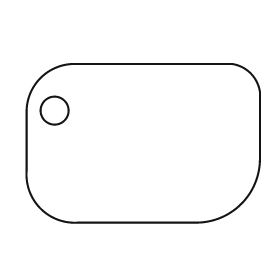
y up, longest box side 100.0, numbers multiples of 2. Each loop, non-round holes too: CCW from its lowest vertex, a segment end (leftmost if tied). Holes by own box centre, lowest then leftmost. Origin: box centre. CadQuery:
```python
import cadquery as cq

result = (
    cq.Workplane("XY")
    .moveTo(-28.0, -34.0)
    .lineTo(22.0, -34.0)
    .threePointArc((42.0, -26.0), (50.0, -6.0))
    .lineTo(50.0, 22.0)
    .threePointArc((46.0, 30.0), (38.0, 34.0))
    .lineTo(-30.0, 34.0)
    .threePointArc((-44.0, 28.0), (-50.0, 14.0))
    .lineTo(-50.0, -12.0)
    .threePointArc((-44.0, -28.0), (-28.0, -34.0))
    .close()
    .moveTo(-38.0, 14.0)
    .circle(6.0)
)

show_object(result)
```